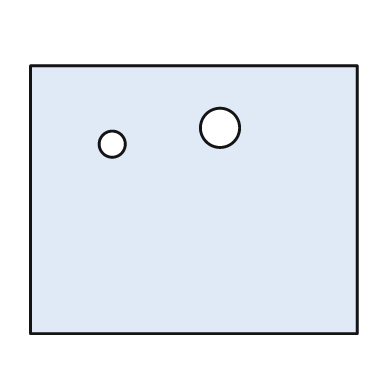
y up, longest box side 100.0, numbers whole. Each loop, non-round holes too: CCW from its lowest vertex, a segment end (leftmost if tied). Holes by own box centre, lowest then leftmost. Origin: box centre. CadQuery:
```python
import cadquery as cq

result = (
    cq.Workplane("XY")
    .moveTo(-50.0, -41.0)
    .lineTo(50.0, -41.0)
    .lineTo(50.0, 41.0)
    .lineTo(-50.0, 41.0)
    .close()
    .moveTo(-25.0, 17.0)
    .circle(4.0)
    .moveTo(8.0, 22.0)
    .circle(6.0)
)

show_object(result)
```